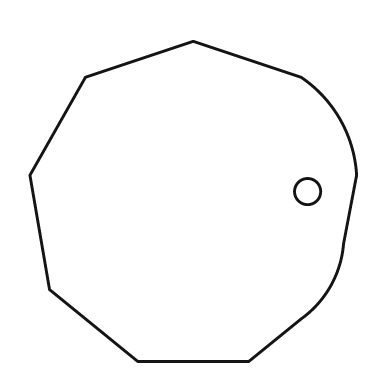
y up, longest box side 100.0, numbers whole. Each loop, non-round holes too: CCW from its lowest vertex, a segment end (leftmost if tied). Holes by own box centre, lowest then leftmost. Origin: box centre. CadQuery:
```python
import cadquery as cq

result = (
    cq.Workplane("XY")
    .moveTo(-17.0, -49.0)
    .lineTo(17.0, -49.0)
    .lineTo(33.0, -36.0)
    .threePointArc((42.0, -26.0), (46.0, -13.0))
    .lineTo(50.0, 8.0)
    .threePointArc((45.0, 25.0), (33.0, 38.0))
    .lineTo(0.0, 49.0)
    .lineTo(-33.0, 38.0)
    .lineTo(-50.0, 8.0)
    .lineTo(-44.0, -27.0)
    .close()
    .moveTo(35.0, 3.0)
    .circle(4.0)
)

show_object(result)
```